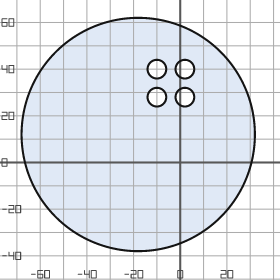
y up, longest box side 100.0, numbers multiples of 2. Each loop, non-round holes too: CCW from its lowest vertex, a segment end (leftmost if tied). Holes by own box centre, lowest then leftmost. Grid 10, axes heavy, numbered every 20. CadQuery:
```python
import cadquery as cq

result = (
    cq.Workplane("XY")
    .moveTo(-18.0, 12.0)
    .circle(50.0)
    .moveTo(-10.0, 28.0)
    .circle(4.0)
    .moveTo(2.0, 28.0)
    .circle(4.0)
    .moveTo(-10.0, 40.0)
    .circle(4.0)
    .moveTo(2.0, 40.0)
    .circle(4.0)
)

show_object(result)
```